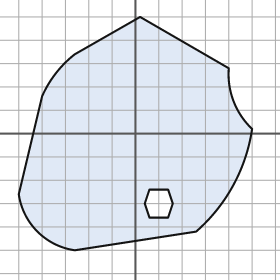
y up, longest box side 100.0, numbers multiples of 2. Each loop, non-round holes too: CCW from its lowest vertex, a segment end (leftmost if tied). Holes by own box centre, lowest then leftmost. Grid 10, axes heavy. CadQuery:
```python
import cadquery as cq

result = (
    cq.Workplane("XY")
    .moveTo(-26.0, -50.0)
    .lineTo(26.0, -42.0)
    .threePointArc((42.0, -22.0), (50.0, 2.0))
    .threePointArc((42.0, 14.0), (40.0, 28.0))
    .lineTo(2.0, 50.0)
    .lineTo(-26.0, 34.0)
    .threePointArc((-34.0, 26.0), (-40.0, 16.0))
    .lineTo(-50.0, -26.0)
    .threePointArc((-42.0, -42.0), (-26.0, -50.0))
    .close()
    .moveTo(6.0, -36.0)
    .lineTo(14.0, -36.0)
    .lineTo(16.0, -30.0)
    .lineTo(14.0, -24.0)
    .lineTo(6.0, -24.0)
    .lineTo(4.0, -30.0)
    .close()
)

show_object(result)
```